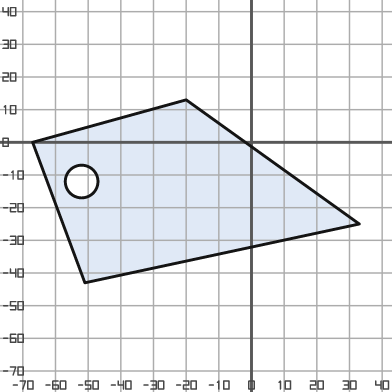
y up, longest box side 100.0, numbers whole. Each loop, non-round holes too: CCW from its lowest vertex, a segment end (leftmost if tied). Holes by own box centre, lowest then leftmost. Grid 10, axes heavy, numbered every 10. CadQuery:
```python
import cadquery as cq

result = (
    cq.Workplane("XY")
    .moveTo(-51.0, -43.0)
    .lineTo(33.0, -25.0)
    .lineTo(-20.0, 13.0)
    .lineTo(-67.0, 0.0)
    .close()
    .moveTo(-52.0, -12.0)
    .circle(5.0)
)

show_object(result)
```